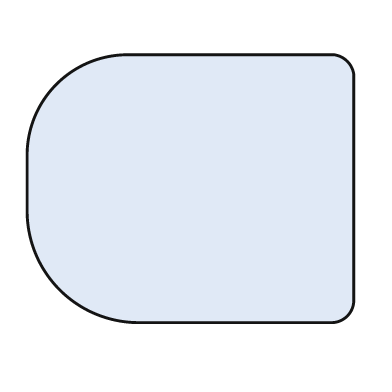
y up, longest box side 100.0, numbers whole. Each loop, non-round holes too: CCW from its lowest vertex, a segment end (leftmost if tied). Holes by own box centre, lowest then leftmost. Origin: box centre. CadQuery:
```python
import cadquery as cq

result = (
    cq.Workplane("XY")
    .moveTo(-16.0, -41.0)
    .lineTo(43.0, -41.0)
    .threePointArc((48.0, -39.0), (50.0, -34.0))
    .lineTo(50.0, 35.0)
    .threePointArc((48.0, 39.0), (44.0, 41.0))
    .lineTo(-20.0, 41.0)
    .threePointArc((-41.0, 32.0), (-50.0, 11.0))
    .lineTo(-50.0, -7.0)
    .threePointArc((-40.0, -31.0), (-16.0, -41.0))
    .close()
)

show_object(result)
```